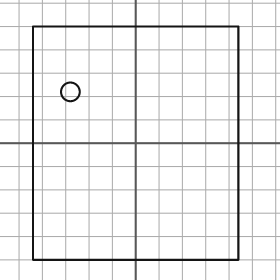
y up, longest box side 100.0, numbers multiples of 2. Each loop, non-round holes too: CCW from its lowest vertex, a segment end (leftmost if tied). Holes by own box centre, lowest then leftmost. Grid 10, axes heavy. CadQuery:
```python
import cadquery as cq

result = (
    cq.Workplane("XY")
    .moveTo(-44.0, -50.0)
    .lineTo(44.0, -50.0)
    .lineTo(44.0, 50.0)
    .lineTo(-44.0, 50.0)
    .close()
    .moveTo(-28.0, 22.0)
    .circle(4.0)
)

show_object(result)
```